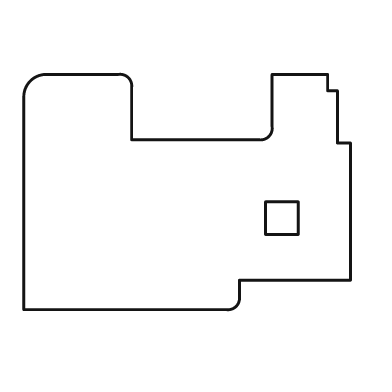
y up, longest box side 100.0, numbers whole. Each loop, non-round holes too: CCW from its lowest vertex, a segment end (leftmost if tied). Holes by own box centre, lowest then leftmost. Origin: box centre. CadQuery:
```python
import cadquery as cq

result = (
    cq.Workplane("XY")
    .moveTo(-50.0, -36.0)
    .lineTo(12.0, -36.0)
    .threePointArc((15.0, -35.0), (16.0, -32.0))
    .lineTo(16.0, -27.0)
    .lineTo(50.0, -27.0)
    .lineTo(50.0, 15.0)
    .lineTo(46.0, 15.0)
    .lineTo(46.0, 31.0)
    .lineTo(43.0, 31.0)
    .lineTo(43.0, 36.0)
    .lineTo(26.0, 36.0)
    .lineTo(26.0, 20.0)
    .threePointArc((25.0, 17.0), (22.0, 16.0))
    .lineTo(-17.0, 16.0)
    .lineTo(-17.0, 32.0)
    .threePointArc((-18.0, 35.0), (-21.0, 36.0))
    .lineTo(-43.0, 36.0)
    .threePointArc((-48.0, 34.0), (-50.0, 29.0))
    .close()
    .moveTo(24.0, -13.0)
    .lineTo(34.0, -13.0)
    .lineTo(34.0, -3.0)
    .lineTo(24.0, -3.0)
    .close()
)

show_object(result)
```